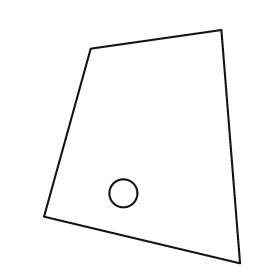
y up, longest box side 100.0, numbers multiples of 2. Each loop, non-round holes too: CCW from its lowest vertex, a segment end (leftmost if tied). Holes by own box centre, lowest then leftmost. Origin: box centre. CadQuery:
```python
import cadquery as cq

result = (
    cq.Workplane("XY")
    .moveTo(42.0, -50.0)
    .lineTo(34.0, 50.0)
    .lineTo(-22.0, 42.0)
    .lineTo(-42.0, -30.0)
    .close()
    .moveTo(-8.0, -20.0)
    .circle(6.0)
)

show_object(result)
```